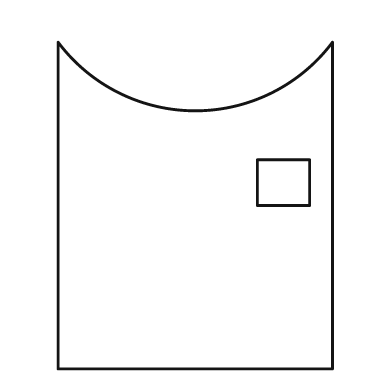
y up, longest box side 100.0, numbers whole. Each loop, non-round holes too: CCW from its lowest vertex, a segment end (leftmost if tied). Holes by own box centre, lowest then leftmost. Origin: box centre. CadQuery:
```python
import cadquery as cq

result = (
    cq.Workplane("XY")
    .moveTo(-42.0, -50.0)
    .lineTo(42.0, -50.0)
    .lineTo(42.0, 50.0)
    .threePointArc((0.0, 29.0), (-42.0, 50.0))
    .close()
    .moveTo(19.0, 0.0)
    .lineTo(35.0, 0.0)
    .lineTo(35.0, 14.0)
    .lineTo(19.0, 14.0)
    .close()
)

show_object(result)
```